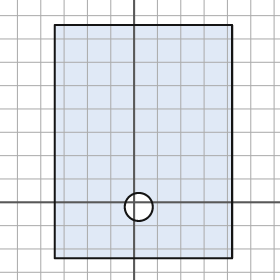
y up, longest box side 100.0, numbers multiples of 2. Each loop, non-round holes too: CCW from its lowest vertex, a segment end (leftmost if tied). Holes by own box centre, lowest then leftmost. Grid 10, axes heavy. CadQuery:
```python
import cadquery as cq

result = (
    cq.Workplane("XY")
    .moveTo(-34.0, -24.0)
    .lineTo(42.0, -24.0)
    .lineTo(42.0, 76.0)
    .lineTo(-34.0, 76.0)
    .close()
    .moveTo(2.0, -2.0)
    .circle(6.0)
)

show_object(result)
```